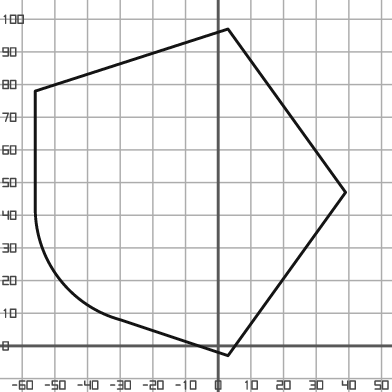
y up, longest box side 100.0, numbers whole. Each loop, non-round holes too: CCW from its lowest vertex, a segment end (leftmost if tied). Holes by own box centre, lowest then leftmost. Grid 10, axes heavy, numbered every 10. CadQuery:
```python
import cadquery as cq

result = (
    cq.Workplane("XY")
    .moveTo(3.0, -3.0)
    .lineTo(39.0, 47.0)
    .lineTo(3.0, 97.0)
    .lineTo(-56.0, 78.0)
    .lineTo(-56.0, 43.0)
    .threePointArc((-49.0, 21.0), (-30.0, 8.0))
    .close()
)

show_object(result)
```